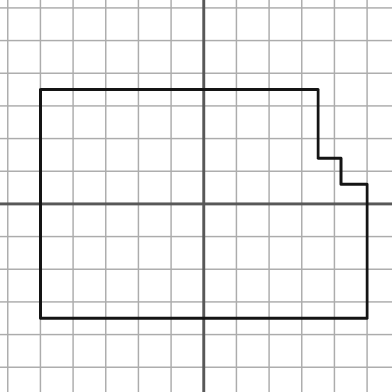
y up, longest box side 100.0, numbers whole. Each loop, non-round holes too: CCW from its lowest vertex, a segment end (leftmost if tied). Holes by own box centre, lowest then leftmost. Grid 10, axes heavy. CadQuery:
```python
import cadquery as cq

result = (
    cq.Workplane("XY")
    .moveTo(-50.0, -35.0)
    .lineTo(50.0, -35.0)
    .lineTo(50.0, 6.0)
    .lineTo(42.0, 6.0)
    .lineTo(42.0, 14.0)
    .lineTo(35.0, 14.0)
    .lineTo(35.0, 35.0)
    .lineTo(-50.0, 35.0)
    .close()
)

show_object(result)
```